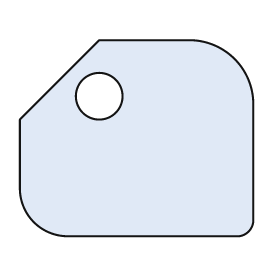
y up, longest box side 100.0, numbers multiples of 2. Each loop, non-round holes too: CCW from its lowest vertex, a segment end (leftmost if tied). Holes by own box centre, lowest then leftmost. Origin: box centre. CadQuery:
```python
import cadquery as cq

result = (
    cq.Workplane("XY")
    .moveTo(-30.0, -42.0)
    .lineTo(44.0, -42.0)
    .threePointArc((48.0, -40.0), (50.0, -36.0))
    .lineTo(50.0, 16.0)
    .threePointArc((42.0, 34.0), (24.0, 42.0))
    .lineTo(-16.0, 42.0)
    .lineTo(-50.0, 8.0)
    .lineTo(-50.0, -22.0)
    .threePointArc((-44.0, -36.0), (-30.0, -42.0))
    .close()
    .moveTo(-16.0, 18.0)
    .circle(10.0)
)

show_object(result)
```